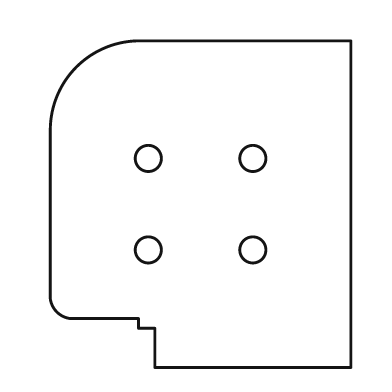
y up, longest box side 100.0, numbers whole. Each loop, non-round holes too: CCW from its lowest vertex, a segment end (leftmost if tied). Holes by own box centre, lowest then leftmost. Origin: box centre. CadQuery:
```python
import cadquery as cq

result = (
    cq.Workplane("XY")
    .moveTo(-14.0, -50.0)
    .lineTo(46.0, -50.0)
    .lineTo(46.0, 50.0)
    .lineTo(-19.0, 50.0)
    .threePointArc((-38.0, 42.0), (-46.0, 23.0))
    .lineTo(-46.0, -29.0)
    .threePointArc((-44.0, -33.0), (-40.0, -35.0))
    .lineTo(-19.0, -35.0)
    .lineTo(-19.0, -38.0)
    .lineTo(-14.0, -38.0)
    .close()
    .moveTo(-16.0, -14.0)
    .circle(4.0)
    .moveTo(16.0, -14.0)
    .circle(4.0)
    .moveTo(-16.0, 14.0)
    .circle(4.0)
    .moveTo(16.0, 14.0)
    .circle(4.0)
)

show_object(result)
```